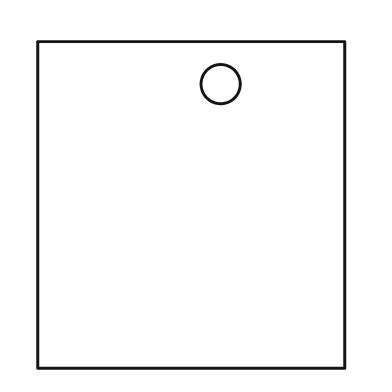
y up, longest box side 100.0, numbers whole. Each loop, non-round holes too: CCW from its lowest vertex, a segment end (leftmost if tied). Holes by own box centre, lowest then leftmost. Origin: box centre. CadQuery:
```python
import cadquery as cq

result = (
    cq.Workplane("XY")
    .moveTo(-47.0, -50.0)
    .lineTo(47.0, -50.0)
    .lineTo(47.0, 50.0)
    .lineTo(-47.0, 50.0)
    .close()
    .moveTo(9.0, 37.0)
    .circle(6.0)
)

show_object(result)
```